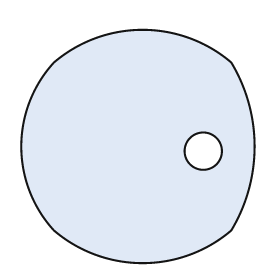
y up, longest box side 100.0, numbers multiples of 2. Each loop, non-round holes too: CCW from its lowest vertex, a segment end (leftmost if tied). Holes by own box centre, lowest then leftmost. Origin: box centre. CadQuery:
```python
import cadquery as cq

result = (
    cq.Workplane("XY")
    .moveTo(-36.0, -36.0)
    .threePointArc((2.0, -50.0), (40.0, -36.0))
    .threePointArc((50.0, 0.0), (40.0, 36.0))
    .threePointArc((2.0, 50.0), (-36.0, 36.0))
    .threePointArc((-50.0, 0.0), (-36.0, -36.0))
    .close()
    .moveTo(28.0, -2.0)
    .circle(8.0)
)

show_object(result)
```